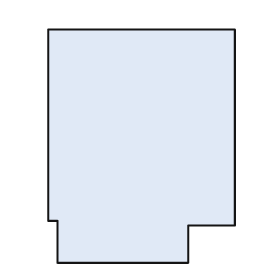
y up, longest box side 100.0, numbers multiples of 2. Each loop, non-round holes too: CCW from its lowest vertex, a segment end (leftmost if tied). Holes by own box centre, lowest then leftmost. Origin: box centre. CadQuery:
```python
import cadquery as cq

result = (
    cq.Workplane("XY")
    .moveTo(-36.0, -50.0)
    .lineTo(20.0, -50.0)
    .lineTo(20.0, -34.0)
    .lineTo(40.0, -34.0)
    .lineTo(40.0, 50.0)
    .lineTo(-40.0, 50.0)
    .lineTo(-40.0, -32.0)
    .lineTo(-36.0, -32.0)
    .close()
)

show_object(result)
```